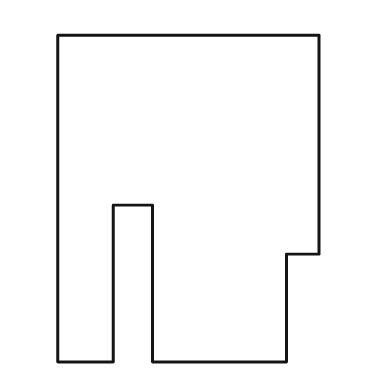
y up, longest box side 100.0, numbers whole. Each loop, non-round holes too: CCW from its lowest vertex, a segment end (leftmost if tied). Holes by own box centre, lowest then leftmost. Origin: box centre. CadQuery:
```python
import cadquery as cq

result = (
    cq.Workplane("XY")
    .moveTo(-40.0, -50.0)
    .lineTo(-23.0, -50.0)
    .lineTo(-23.0, -2.0)
    .lineTo(-11.0, -2.0)
    .lineTo(-11.0, -50.0)
    .lineTo(30.0, -50.0)
    .lineTo(30.0, -17.0)
    .lineTo(40.0, -17.0)
    .lineTo(40.0, 50.0)
    .lineTo(-40.0, 50.0)
    .close()
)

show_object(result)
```